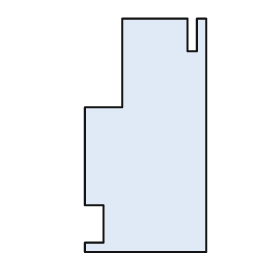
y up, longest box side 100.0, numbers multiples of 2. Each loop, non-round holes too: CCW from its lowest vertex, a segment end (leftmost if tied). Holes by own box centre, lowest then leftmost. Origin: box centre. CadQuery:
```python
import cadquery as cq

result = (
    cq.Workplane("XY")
    .moveTo(-26.0, -50.0)
    .lineTo(26.0, -50.0)
    .lineTo(26.0, 50.0)
    .lineTo(22.0, 50.0)
    .lineTo(22.0, 36.0)
    .lineTo(18.0, 36.0)
    .lineTo(18.0, 50.0)
    .lineTo(-10.0, 50.0)
    .lineTo(-10.0, 12.0)
    .lineTo(-26.0, 12.0)
    .lineTo(-26.0, -30.0)
    .lineTo(-18.0, -30.0)
    .lineTo(-18.0, -46.0)
    .lineTo(-26.0, -46.0)
    .close()
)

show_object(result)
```